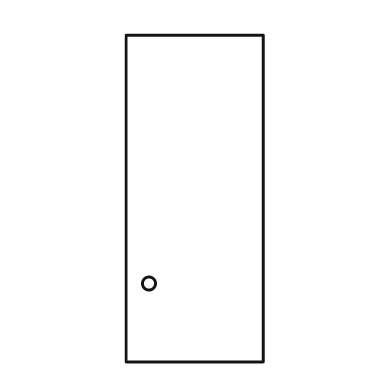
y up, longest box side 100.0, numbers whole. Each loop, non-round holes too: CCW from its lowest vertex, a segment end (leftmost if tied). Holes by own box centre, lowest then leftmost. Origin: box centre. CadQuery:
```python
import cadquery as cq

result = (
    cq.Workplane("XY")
    .moveTo(-21.0, -50.0)
    .lineTo(21.0, -50.0)
    .lineTo(21.0, 50.0)
    .lineTo(-21.0, 50.0)
    .close()
    .moveTo(-14.0, -26.0)
    .circle(2.0)
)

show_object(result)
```